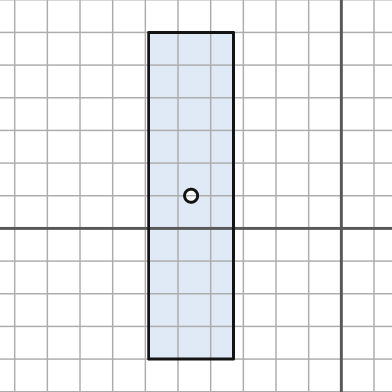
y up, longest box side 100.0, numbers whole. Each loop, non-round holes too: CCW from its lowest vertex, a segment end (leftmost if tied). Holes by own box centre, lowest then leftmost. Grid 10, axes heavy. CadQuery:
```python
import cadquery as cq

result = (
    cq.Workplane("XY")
    .moveTo(-59.0, -40.0)
    .lineTo(-33.0, -40.0)
    .lineTo(-33.0, 60.0)
    .lineTo(-59.0, 60.0)
    .close()
    .moveTo(-46.0, 10.0)
    .circle(2.0)
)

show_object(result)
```